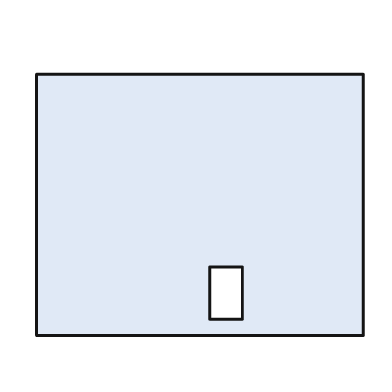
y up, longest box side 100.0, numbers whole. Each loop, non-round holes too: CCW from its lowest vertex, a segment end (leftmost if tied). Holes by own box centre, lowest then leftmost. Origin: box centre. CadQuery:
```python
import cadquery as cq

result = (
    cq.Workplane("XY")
    .moveTo(-50.0, -40.0)
    .lineTo(50.0, -40.0)
    .lineTo(50.0, 40.0)
    .lineTo(-50.0, 40.0)
    .close()
    .moveTo(3.0, -35.0)
    .lineTo(13.0, -35.0)
    .lineTo(13.0, -19.0)
    .lineTo(3.0, -19.0)
    .close()
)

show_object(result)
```